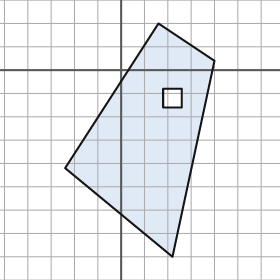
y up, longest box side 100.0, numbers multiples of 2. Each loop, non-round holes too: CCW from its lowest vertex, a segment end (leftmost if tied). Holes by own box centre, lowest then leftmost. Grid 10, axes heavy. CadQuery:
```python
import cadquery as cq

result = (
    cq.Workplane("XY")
    .moveTo(22.0, -80.0)
    .lineTo(40.0, 4.0)
    .lineTo(16.0, 20.0)
    .lineTo(-24.0, -42.0)
    .close()
    .moveTo(18.0, -16.0)
    .lineTo(26.0, -16.0)
    .lineTo(26.0, -8.0)
    .lineTo(18.0, -8.0)
    .close()
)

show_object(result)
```